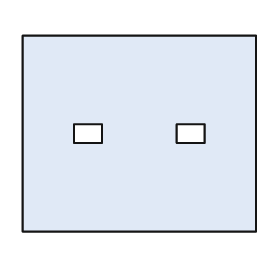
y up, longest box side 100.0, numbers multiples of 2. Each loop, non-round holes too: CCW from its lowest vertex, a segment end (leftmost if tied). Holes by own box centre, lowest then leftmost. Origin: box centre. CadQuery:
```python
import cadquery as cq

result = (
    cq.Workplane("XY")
    .moveTo(-50.0, -42.0)
    .lineTo(50.0, -42.0)
    .lineTo(50.0, 42.0)
    .lineTo(-50.0, 42.0)
    .close()
    .moveTo(-28.0, -4.0)
    .lineTo(-16.0, -4.0)
    .lineTo(-16.0, 4.0)
    .lineTo(-28.0, 4.0)
    .close()
    .moveTo(16.0, -4.0)
    .lineTo(28.0, -4.0)
    .lineTo(28.0, 4.0)
    .lineTo(16.0, 4.0)
    .close()
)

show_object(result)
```